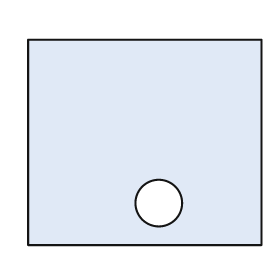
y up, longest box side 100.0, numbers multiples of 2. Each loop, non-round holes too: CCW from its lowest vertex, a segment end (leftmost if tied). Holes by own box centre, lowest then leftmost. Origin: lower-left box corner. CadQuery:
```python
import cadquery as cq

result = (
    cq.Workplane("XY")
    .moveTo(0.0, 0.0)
    .lineTo(100.0, 0.0)
    .lineTo(100.0, 88.0)
    .lineTo(0.0, 88.0)
    .close()
    .moveTo(56.0, 18.0)
    .circle(10.0)
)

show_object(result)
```